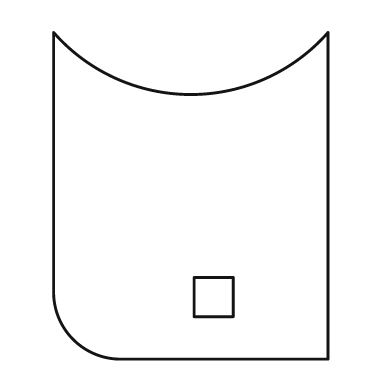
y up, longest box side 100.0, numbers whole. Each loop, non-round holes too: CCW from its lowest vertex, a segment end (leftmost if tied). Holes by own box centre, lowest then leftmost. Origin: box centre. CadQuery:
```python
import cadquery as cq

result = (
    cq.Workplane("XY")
    .moveTo(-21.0, -50.0)
    .lineTo(42.0, -50.0)
    .lineTo(42.0, 50.0)
    .threePointArc((0.0, 31.0), (-42.0, 50.0))
    .lineTo(-42.0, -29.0)
    .threePointArc((-36.0, -44.0), (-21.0, -50.0))
    .close()
    .moveTo(1.0, -37.0)
    .lineTo(13.0, -37.0)
    .lineTo(13.0, -25.0)
    .lineTo(1.0, -25.0)
    .close()
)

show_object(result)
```